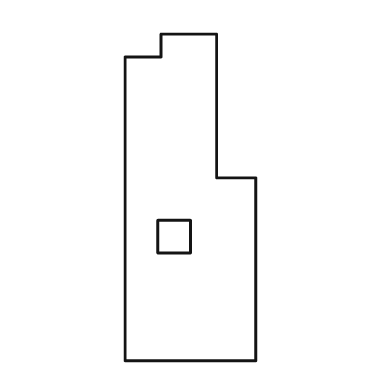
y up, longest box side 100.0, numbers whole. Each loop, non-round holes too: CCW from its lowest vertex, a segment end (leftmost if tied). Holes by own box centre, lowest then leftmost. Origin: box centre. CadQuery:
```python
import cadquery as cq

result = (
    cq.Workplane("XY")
    .moveTo(-20.0, -50.0)
    .lineTo(20.0, -50.0)
    .lineTo(20.0, 6.0)
    .lineTo(8.0, 6.0)
    .lineTo(8.0, 50.0)
    .lineTo(-9.0, 50.0)
    .lineTo(-9.0, 43.0)
    .lineTo(-20.0, 43.0)
    .close()
    .moveTo(-10.0, -17.0)
    .lineTo(0.0, -17.0)
    .lineTo(0.0, -7.0)
    .lineTo(-10.0, -7.0)
    .close()
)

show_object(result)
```